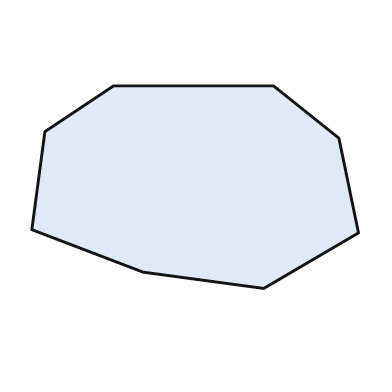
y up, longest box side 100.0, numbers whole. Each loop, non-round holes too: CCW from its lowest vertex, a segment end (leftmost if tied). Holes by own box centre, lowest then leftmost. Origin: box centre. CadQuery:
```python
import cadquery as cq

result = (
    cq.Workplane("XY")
    .moveTo(21.0, -31.0)
    .lineTo(50.0, -14.0)
    .lineTo(44.0, 15.0)
    .lineTo(24.0, 31.0)
    .lineTo(-25.0, 31.0)
    .lineTo(-46.0, 17.0)
    .lineTo(-50.0, -13.0)
    .lineTo(-16.0, -26.0)
    .close()
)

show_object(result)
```